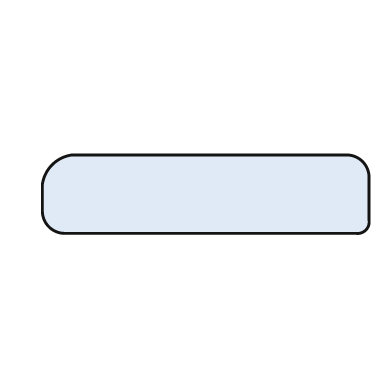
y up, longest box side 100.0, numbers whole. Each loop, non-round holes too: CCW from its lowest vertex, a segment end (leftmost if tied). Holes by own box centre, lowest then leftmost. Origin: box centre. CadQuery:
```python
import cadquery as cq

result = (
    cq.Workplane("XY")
    .moveTo(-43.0, -12.0)
    .lineTo(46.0, -12.0)
    .threePointArc((49.0, -11.0), (50.0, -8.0))
    .lineTo(50.0, 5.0)
    .threePointArc((48.0, 10.0), (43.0, 12.0))
    .lineTo(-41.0, 12.0)
    .threePointArc((-47.0, 9.0), (-50.0, 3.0))
    .lineTo(-50.0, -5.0)
    .threePointArc((-48.0, -10.0), (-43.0, -12.0))
    .close()
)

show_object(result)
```